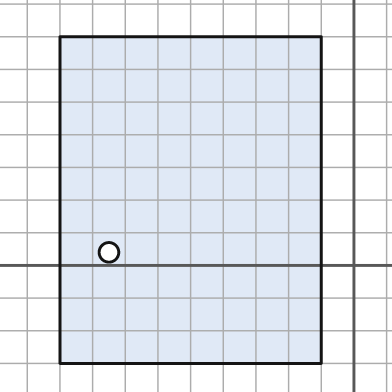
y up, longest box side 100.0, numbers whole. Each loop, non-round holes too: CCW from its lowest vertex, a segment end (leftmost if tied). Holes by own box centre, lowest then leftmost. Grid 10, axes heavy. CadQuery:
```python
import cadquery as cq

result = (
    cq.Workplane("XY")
    .moveTo(-90.0, -30.0)
    .lineTo(-10.0, -30.0)
    .lineTo(-10.0, 70.0)
    .lineTo(-90.0, 70.0)
    .close()
    .moveTo(-75.0, 4.0)
    .circle(3.0)
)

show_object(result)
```